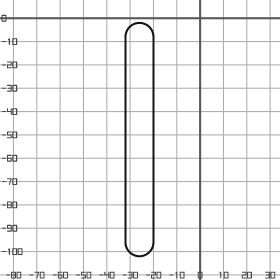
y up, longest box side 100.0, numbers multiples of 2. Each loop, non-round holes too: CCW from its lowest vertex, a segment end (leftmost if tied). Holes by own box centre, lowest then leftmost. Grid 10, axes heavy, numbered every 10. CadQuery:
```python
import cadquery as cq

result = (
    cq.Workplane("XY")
    .moveTo(-32.0, -96.0)
    .threePointArc((-26.0, -102.0), (-20.0, -96.0))
    .lineTo(-20.0, -8.0)
    .threePointArc((-26.0, -2.0), (-32.0, -8.0))
    .close()
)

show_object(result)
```